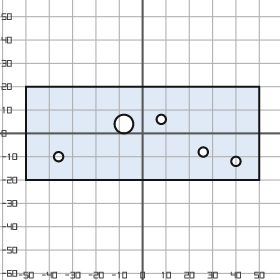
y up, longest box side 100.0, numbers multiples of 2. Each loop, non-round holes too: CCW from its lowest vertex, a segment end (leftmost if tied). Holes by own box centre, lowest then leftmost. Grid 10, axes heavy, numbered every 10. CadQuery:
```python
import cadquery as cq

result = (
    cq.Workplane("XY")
    .moveTo(-50.0, -20.0)
    .lineTo(50.0, -20.0)
    .lineTo(50.0, 20.0)
    .lineTo(-50.0, 20.0)
    .close()
    .moveTo(40.0, -12.0)
    .circle(2.0)
    .moveTo(-36.0, -10.0)
    .circle(2.0)
    .moveTo(26.0, -8.0)
    .circle(2.0)
    .moveTo(-8.0, 4.0)
    .circle(4.0)
    .moveTo(8.0, 6.0)
    .circle(2.0)
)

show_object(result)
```